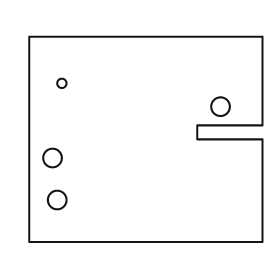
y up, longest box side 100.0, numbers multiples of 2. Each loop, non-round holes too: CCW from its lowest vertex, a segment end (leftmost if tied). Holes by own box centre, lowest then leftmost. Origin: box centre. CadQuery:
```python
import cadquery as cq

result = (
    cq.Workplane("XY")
    .moveTo(-50.0, -44.0)
    .lineTo(50.0, -44.0)
    .lineTo(50.0, 0.0)
    .lineTo(22.0, 0.0)
    .lineTo(22.0, 6.0)
    .lineTo(50.0, 6.0)
    .lineTo(50.0, 44.0)
    .lineTo(-50.0, 44.0)
    .close()
    .moveTo(-38.0, -26.0)
    .circle(4.0)
    .moveTo(-40.0, -8.0)
    .circle(4.0)
    .moveTo(32.0, 14.0)
    .circle(4.0)
    .moveTo(-36.0, 24.0)
    .circle(2.0)
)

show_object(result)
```